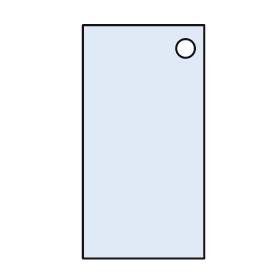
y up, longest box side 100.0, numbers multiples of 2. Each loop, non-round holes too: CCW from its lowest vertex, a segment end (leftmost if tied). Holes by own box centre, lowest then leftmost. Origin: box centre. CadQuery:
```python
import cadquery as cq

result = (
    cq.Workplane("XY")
    .moveTo(-26.0, -50.0)
    .lineTo(26.0, -50.0)
    .lineTo(26.0, 50.0)
    .lineTo(-26.0, 50.0)
    .close()
    .moveTo(18.0, 40.0)
    .circle(4.0)
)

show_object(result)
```